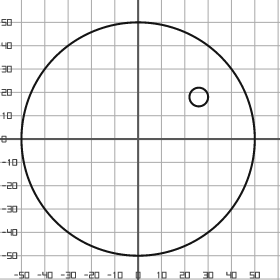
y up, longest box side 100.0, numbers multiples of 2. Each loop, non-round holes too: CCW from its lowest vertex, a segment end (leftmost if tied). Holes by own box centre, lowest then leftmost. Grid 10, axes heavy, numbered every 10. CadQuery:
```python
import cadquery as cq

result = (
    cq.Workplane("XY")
    .moveTo(0.0, 0.0)
    .circle(50.0)
    .moveTo(26.0, 18.0)
    .circle(4.0)
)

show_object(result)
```